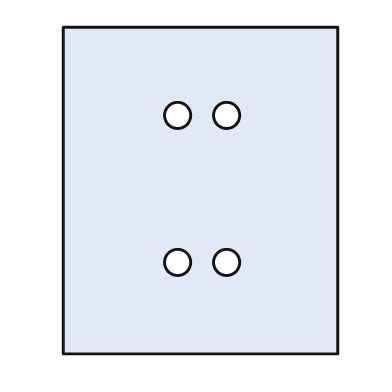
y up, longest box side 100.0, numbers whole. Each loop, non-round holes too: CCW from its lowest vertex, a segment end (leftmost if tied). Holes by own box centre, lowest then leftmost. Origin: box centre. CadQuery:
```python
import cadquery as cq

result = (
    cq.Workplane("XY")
    .moveTo(-42.0, -50.0)
    .lineTo(42.0, -50.0)
    .lineTo(42.0, 50.0)
    .lineTo(-42.0, 50.0)
    .close()
    .moveTo(-7.0, -22.0)
    .circle(4.0)
    .moveTo(8.0, -22.0)
    .circle(4.0)
    .moveTo(-7.0, 23.0)
    .circle(4.0)
    .moveTo(8.0, 23.0)
    .circle(4.0)
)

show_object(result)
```